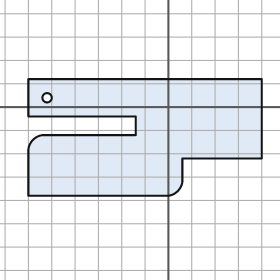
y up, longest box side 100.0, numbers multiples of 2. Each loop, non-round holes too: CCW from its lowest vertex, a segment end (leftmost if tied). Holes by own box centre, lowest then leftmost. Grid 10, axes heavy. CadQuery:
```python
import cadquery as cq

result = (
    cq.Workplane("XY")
    .moveTo(-60.0, -38.0)
    .lineTo(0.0, -38.0)
    .threePointArc((4.0, -36.0), (6.0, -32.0))
    .lineTo(6.0, -22.0)
    .lineTo(40.0, -22.0)
    .lineTo(40.0, 12.0)
    .lineTo(-60.0, 12.0)
    .lineTo(-60.0, -4.0)
    .lineTo(-14.0, -4.0)
    .lineTo(-14.0, -12.0)
    .lineTo(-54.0, -12.0)
    .threePointArc((-58.0, -14.0), (-60.0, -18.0))
    .close()
    .moveTo(-52.0, 4.0)
    .circle(2.0)
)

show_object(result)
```